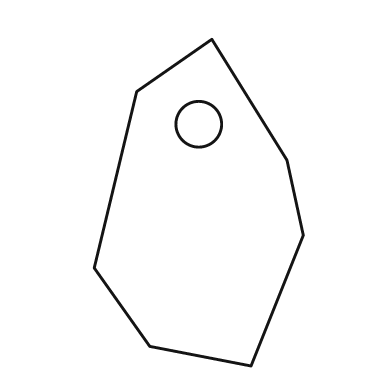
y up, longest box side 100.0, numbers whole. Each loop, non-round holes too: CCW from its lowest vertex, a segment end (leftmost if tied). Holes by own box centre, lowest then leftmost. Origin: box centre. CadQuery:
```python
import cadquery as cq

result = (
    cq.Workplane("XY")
    .moveTo(16.0, -50.0)
    .lineTo(32.0, -10.0)
    .lineTo(27.0, 13.0)
    .lineTo(4.0, 50.0)
    .lineTo(-19.0, 34.0)
    .lineTo(-32.0, -20.0)
    .lineTo(-15.0, -44.0)
    .close()
    .moveTo(0.0, 24.0)
    .circle(7.0)
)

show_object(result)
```